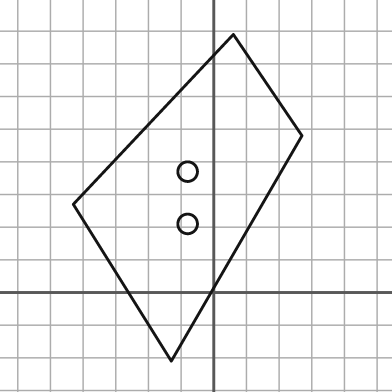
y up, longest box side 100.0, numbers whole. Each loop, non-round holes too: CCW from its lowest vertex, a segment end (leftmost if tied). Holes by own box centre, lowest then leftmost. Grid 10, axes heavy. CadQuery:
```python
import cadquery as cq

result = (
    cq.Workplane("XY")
    .moveTo(-13.0, -21.0)
    .lineTo(27.0, 48.0)
    .lineTo(6.0, 79.0)
    .lineTo(-43.0, 27.0)
    .close()
    .moveTo(-8.0, 21.0)
    .circle(3.0)
    .moveTo(-8.0, 37.0)
    .circle(3.0)
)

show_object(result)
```